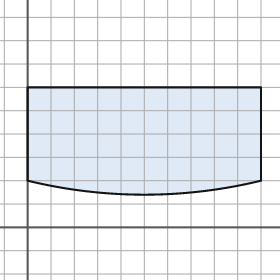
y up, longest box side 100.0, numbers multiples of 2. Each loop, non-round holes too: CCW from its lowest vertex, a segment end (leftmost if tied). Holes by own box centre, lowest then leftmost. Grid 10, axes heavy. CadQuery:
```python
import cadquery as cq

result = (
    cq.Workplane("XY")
    .moveTo(0.0, 20.0)
    .threePointArc((50.0, 14.0), (100.0, 20.0))
    .lineTo(100.0, 60.0)
    .lineTo(0.0, 60.0)
    .close()
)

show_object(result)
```